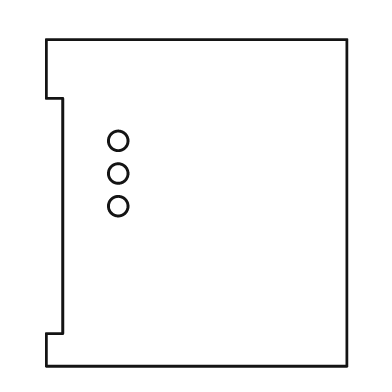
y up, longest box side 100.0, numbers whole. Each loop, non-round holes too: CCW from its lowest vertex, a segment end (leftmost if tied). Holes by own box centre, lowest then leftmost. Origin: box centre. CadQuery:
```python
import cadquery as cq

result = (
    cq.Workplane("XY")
    .moveTo(-46.0, -50.0)
    .lineTo(46.0, -50.0)
    .lineTo(46.0, 50.0)
    .lineTo(-46.0, 50.0)
    .lineTo(-46.0, 32.0)
    .lineTo(-41.0, 32.0)
    .lineTo(-41.0, -40.0)
    .lineTo(-46.0, -40.0)
    .close()
    .moveTo(-24.0, -1.0)
    .circle(3.0)
    .moveTo(-24.0, 9.0)
    .circle(3.0)
    .moveTo(-24.0, 19.0)
    .circle(3.0)
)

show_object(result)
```